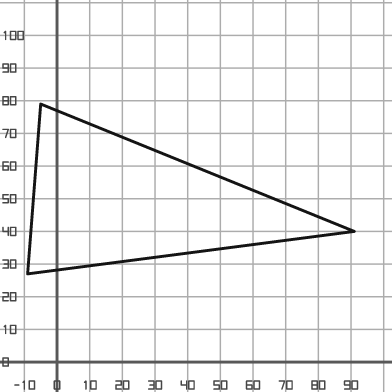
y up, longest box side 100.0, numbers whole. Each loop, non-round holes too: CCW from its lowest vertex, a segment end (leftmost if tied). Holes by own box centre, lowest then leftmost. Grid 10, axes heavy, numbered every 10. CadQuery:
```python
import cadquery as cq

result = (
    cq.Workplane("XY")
    .moveTo(-9.0, 27.0)
    .lineTo(91.0, 40.0)
    .lineTo(-5.0, 79.0)
    .close()
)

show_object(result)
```